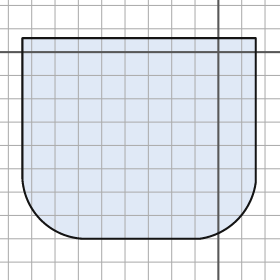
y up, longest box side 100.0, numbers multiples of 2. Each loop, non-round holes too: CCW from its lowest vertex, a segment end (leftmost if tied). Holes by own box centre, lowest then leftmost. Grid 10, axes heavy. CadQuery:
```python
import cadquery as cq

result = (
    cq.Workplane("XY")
    .moveTo(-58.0, -80.0)
    .lineTo(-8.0, -80.0)
    .threePointArc((8.0, -72.0), (16.0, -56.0))
    .lineTo(16.0, 6.0)
    .lineTo(-84.0, 6.0)
    .lineTo(-84.0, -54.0)
    .threePointArc((-76.0, -72.0), (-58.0, -80.0))
    .close()
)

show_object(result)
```